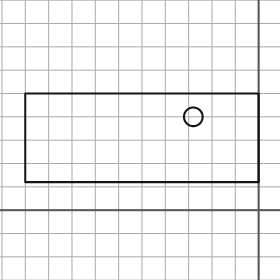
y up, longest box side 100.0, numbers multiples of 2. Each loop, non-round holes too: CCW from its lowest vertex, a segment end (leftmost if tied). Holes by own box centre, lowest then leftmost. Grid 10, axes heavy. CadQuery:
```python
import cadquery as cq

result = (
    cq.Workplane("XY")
    .moveTo(-100.0, 12.0)
    .lineTo(0.0, 12.0)
    .lineTo(0.0, 50.0)
    .lineTo(-100.0, 50.0)
    .close()
    .moveTo(-28.0, 40.0)
    .circle(4.0)
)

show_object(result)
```